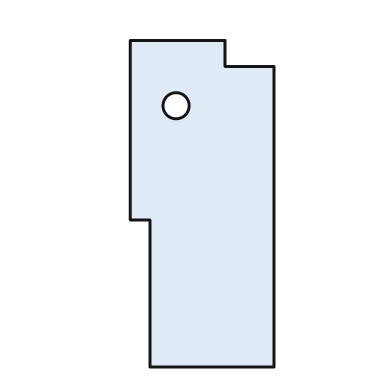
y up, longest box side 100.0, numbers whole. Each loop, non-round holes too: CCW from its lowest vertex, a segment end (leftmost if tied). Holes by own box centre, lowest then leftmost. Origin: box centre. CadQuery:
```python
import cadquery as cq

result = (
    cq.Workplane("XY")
    .moveTo(-16.0, -50.0)
    .lineTo(22.0, -50.0)
    .lineTo(22.0, 42.0)
    .lineTo(7.0, 42.0)
    .lineTo(7.0, 50.0)
    .lineTo(-22.0, 50.0)
    .lineTo(-22.0, -5.0)
    .lineTo(-16.0, -5.0)
    .close()
    .moveTo(-8.0, 30.0)
    .circle(4.0)
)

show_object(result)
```